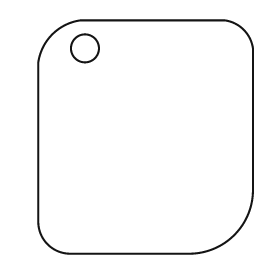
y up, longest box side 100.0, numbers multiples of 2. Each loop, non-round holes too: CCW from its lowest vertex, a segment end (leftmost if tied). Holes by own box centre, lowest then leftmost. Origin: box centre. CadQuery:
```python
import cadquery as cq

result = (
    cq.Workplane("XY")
    .moveTo(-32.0, -50.0)
    .lineTo(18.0, -50.0)
    .threePointArc((38.0, -42.0), (46.0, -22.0))
    .lineTo(46.0, 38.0)
    .threePointArc((42.0, 46.0), (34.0, 50.0))
    .lineTo(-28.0, 50.0)
    .threePointArc((-40.0, 44.0), (-46.0, 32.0))
    .lineTo(-46.0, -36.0)
    .threePointArc((-42.0, -46.0), (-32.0, -50.0))
    .close()
    .moveTo(-26.0, 38.0)
    .circle(6.0)
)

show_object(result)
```